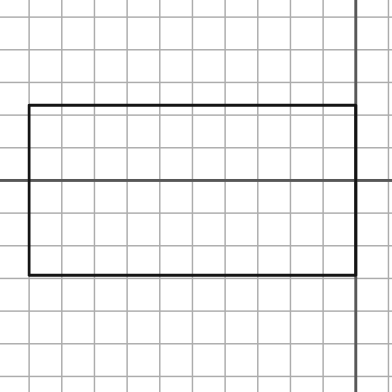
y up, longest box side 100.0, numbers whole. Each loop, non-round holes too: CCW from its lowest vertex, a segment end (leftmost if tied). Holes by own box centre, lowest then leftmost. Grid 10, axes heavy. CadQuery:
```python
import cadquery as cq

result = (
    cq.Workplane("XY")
    .moveTo(-100.0, -29.0)
    .lineTo(0.0, -29.0)
    .lineTo(0.0, 23.0)
    .lineTo(-100.0, 23.0)
    .close()
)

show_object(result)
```